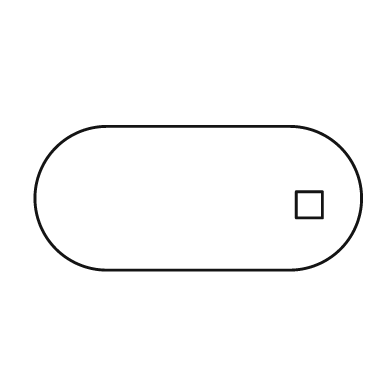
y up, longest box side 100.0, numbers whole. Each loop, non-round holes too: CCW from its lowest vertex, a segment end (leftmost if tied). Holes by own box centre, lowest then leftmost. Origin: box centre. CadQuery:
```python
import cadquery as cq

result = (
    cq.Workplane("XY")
    .moveTo(-28.0, -22.0)
    .lineTo(28.0, -22.0)
    .threePointArc((50.0, 0.0), (28.0, 22.0))
    .lineTo(-28.0, 22.0)
    .threePointArc((-50.0, 0.0), (-28.0, -22.0))
    .close()
    .moveTo(30.0, -6.0)
    .lineTo(38.0, -6.0)
    .lineTo(38.0, 2.0)
    .lineTo(30.0, 2.0)
    .close()
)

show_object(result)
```